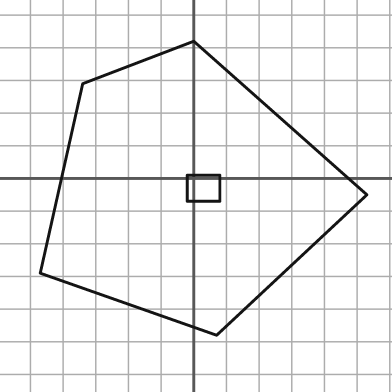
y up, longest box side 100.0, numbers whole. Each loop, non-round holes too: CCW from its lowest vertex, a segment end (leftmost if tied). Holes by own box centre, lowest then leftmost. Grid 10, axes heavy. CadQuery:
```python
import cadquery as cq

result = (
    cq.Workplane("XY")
    .moveTo(7.0, -48.0)
    .lineTo(53.0, -5.0)
    .lineTo(0.0, 42.0)
    .lineTo(-34.0, 29.0)
    .lineTo(-47.0, -29.0)
    .close()
    .moveTo(-2.0, -7.0)
    .lineTo(8.0, -7.0)
    .lineTo(8.0, 1.0)
    .lineTo(-2.0, 1.0)
    .close()
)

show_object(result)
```